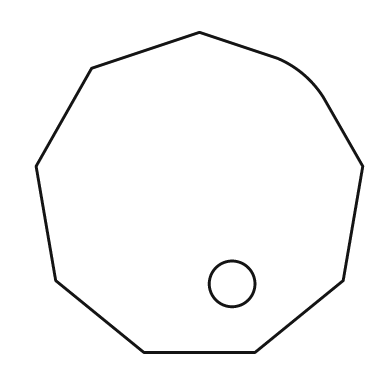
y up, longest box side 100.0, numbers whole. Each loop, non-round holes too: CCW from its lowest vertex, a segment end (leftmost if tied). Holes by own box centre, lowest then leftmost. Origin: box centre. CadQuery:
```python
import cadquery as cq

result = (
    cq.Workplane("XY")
    .moveTo(-17.0, -49.0)
    .lineTo(17.0, -49.0)
    .lineTo(44.0, -27.0)
    .lineTo(50.0, 8.0)
    .lineTo(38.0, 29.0)
    .threePointArc((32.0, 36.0), (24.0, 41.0))
    .lineTo(0.0, 49.0)
    .lineTo(-33.0, 38.0)
    .lineTo(-50.0, 8.0)
    .lineTo(-44.0, -27.0)
    .close()
    .moveTo(10.0, -28.0)
    .circle(7.0)
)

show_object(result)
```